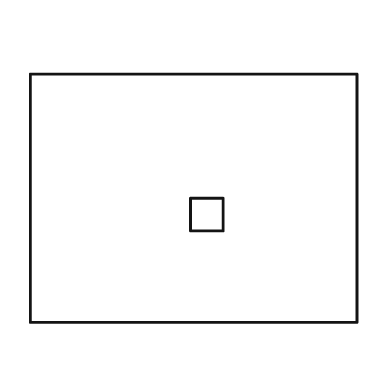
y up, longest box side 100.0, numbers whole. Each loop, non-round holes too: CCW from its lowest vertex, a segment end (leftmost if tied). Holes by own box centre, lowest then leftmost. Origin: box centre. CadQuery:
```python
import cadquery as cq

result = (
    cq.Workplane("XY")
    .moveTo(-50.0, -38.0)
    .lineTo(50.0, -38.0)
    .lineTo(50.0, 38.0)
    .lineTo(-50.0, 38.0)
    .close()
    .moveTo(-1.0, -10.0)
    .lineTo(9.0, -10.0)
    .lineTo(9.0, 0.0)
    .lineTo(-1.0, 0.0)
    .close()
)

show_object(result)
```